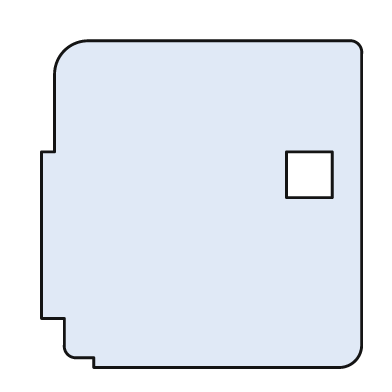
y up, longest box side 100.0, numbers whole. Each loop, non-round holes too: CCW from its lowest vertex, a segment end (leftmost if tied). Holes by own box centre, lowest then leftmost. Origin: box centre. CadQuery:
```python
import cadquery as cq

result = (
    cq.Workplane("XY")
    .moveTo(-33.0, -50.0)
    .lineTo(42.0, -50.0)
    .threePointArc((47.0, -48.0), (49.0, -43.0))
    .lineTo(49.0, 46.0)
    .threePointArc((48.0, 49.0), (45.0, 50.0))
    .lineTo(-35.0, 50.0)
    .threePointArc((-42.0, 47.0), (-45.0, 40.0))
    .lineTo(-45.0, 16.0)
    .lineTo(-49.0, 16.0)
    .lineTo(-49.0, -35.0)
    .lineTo(-42.0, -35.0)
    .lineTo(-42.0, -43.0)
    .threePointArc((-41.0, -46.0), (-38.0, -47.0))
    .lineTo(-33.0, -47.0)
    .close()
    .moveTo(26.0, 2.0)
    .lineTo(40.0, 2.0)
    .lineTo(40.0, 16.0)
    .lineTo(26.0, 16.0)
    .close()
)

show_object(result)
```